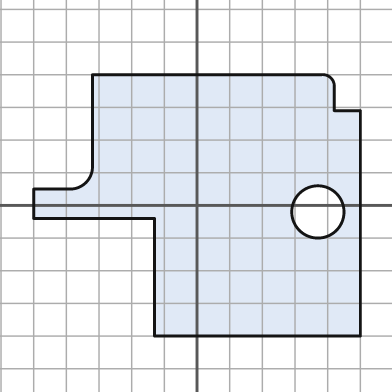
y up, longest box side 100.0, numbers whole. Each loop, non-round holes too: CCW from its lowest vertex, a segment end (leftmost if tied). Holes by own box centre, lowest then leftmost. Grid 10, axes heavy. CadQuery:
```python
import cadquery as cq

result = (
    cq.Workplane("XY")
    .moveTo(-13.0, -40.0)
    .lineTo(50.0, -40.0)
    .lineTo(50.0, 29.0)
    .lineTo(42.0, 29.0)
    .lineTo(42.0, 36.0)
    .threePointArc((41.0, 39.0), (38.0, 40.0))
    .lineTo(-32.0, 40.0)
    .lineTo(-32.0, 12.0)
    .threePointArc((-34.0, 7.0), (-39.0, 5.0))
    .lineTo(-50.0, 5.0)
    .lineTo(-50.0, -4.0)
    .lineTo(-13.0, -4.0)
    .close()
    .moveTo(37.0, -2.0)
    .circle(8.0)
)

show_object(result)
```